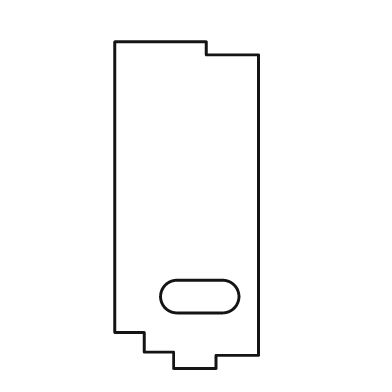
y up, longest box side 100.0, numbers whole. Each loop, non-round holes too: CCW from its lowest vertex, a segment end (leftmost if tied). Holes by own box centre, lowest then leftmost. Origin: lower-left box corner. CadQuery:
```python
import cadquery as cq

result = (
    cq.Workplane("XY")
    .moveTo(18.0, 0.0)
    .lineTo(31.0, 0.0)
    .lineTo(31.0, 4.0)
    .lineTo(44.0, 4.0)
    .lineTo(44.0, 96.0)
    .lineTo(28.0, 96.0)
    .lineTo(28.0, 100.0)
    .lineTo(0.0, 100.0)
    .lineTo(0.0, 11.0)
    .lineTo(9.0, 11.0)
    .lineTo(9.0, 5.0)
    .lineTo(18.0, 5.0)
    .close()
    .moveTo(19.0, 17.0)
    .lineTo(33.0, 17.0)
    .threePointArc((38.0, 22.0), (33.0, 27.0))
    .lineTo(19.0, 27.0)
    .threePointArc((14.0, 22.0), (19.0, 17.0))
    .close()
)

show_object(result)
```